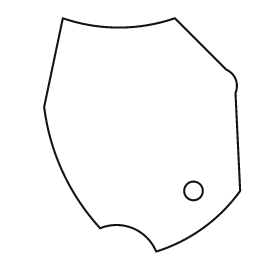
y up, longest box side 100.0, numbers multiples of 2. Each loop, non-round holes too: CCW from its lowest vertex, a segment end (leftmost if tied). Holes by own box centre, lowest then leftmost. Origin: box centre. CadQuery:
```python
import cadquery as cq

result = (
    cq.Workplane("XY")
    .moveTo(6.0, -50.0)
    .threePointArc((26.0, -40.0), (42.0, -24.0))
    .lineTo(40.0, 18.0)
    .threePointArc((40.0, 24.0), (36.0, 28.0))
    .lineTo(14.0, 50.0)
    .threePointArc((-10.0, 46.0), (-34.0, 50.0))
    .lineTo(-42.0, 12.0)
    .threePointArc((-34.0, -16.0), (-18.0, -40.0))
    .threePointArc((-4.0, -40.0), (6.0, -50.0))
    .close()
    .moveTo(22.0, -24.0)
    .circle(4.0)
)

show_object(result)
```